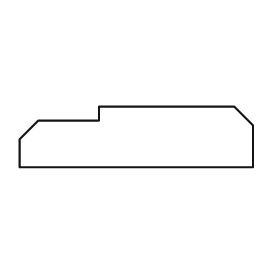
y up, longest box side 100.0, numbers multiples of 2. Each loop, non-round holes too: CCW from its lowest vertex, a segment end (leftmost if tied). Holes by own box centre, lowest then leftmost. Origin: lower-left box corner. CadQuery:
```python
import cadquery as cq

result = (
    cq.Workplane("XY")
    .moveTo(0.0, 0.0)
    .lineTo(100.0, 0.0)
    .lineTo(100.0, 18.0)
    .lineTo(92.0, 26.0)
    .lineTo(34.0, 26.0)
    .lineTo(34.0, 20.0)
    .lineTo(8.0, 20.0)
    .lineTo(0.0, 12.0)
    .close()
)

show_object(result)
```